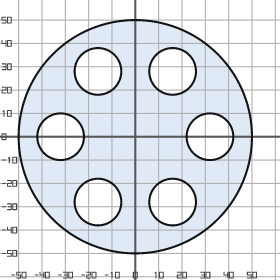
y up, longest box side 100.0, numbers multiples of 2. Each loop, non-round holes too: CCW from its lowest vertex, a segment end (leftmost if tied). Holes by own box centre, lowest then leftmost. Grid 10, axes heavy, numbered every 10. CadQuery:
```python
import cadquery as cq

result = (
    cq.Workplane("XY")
    .moveTo(0.0, 0.0)
    .circle(50.0)
    .moveTo(-16.0, -28.0)
    .circle(10.0)
    .moveTo(16.0, -28.0)
    .circle(10.0)
    .moveTo(-32.0, 0.0)
    .circle(10.0)
    .moveTo(32.0, 0.0)
    .circle(10.0)
    .moveTo(-16.0, 28.0)
    .circle(10.0)
    .moveTo(16.0, 28.0)
    .circle(10.0)
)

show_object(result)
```